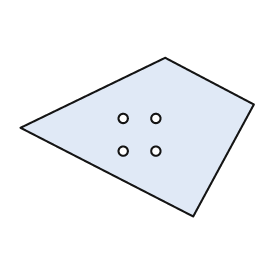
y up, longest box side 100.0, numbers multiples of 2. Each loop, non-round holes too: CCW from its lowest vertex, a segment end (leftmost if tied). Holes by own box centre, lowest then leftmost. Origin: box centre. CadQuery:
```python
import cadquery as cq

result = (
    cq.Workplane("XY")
    .moveTo(24.0, -34.0)
    .lineTo(50.0, 14.0)
    .lineTo(12.0, 34.0)
    .lineTo(-50.0, 4.0)
    .close()
    .moveTo(-6.0, -6.0)
    .circle(2.0)
    .moveTo(8.0, -6.0)
    .circle(2.0)
    .moveTo(-6.0, 8.0)
    .circle(2.0)
    .moveTo(8.0, 8.0)
    .circle(2.0)
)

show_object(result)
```